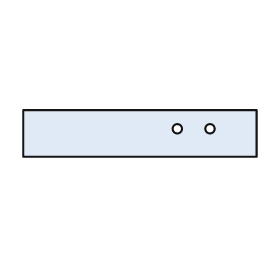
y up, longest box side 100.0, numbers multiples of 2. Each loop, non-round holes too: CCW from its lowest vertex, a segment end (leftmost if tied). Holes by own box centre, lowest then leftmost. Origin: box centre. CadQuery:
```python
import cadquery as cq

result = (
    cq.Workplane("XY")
    .moveTo(-50.0, -10.0)
    .lineTo(50.0, -10.0)
    .lineTo(50.0, 10.0)
    .lineTo(-50.0, 10.0)
    .close()
    .moveTo(16.0, 2.0)
    .circle(2.0)
    .moveTo(30.0, 2.0)
    .circle(2.0)
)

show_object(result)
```